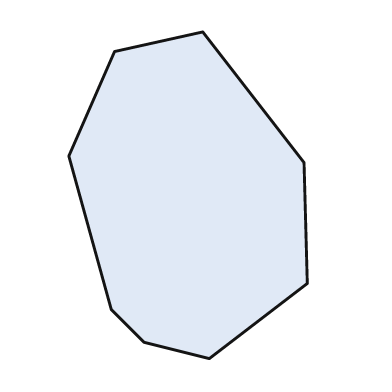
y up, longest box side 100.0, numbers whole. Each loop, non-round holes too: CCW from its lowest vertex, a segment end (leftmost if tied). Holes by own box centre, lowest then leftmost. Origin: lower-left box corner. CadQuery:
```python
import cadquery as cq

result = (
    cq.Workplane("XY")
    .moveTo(43.0, 0.0)
    .lineTo(73.0, 23.0)
    .lineTo(72.0, 60.0)
    .lineTo(41.0, 100.0)
    .lineTo(14.0, 94.0)
    .lineTo(0.0, 62.0)
    .lineTo(13.0, 15.0)
    .lineTo(23.0, 5.0)
    .close()
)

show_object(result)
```